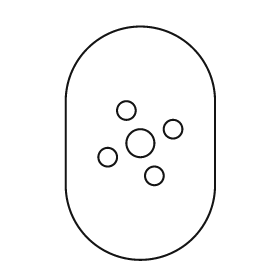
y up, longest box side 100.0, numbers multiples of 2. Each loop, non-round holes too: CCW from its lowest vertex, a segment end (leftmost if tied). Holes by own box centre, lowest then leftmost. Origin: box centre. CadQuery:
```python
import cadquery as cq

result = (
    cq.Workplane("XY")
    .moveTo(-32.0, -18.0)
    .threePointArc((0.0, -50.0), (32.0, -18.0))
    .lineTo(32.0, 18.0)
    .threePointArc((0.0, 50.0), (-32.0, 18.0))
    .close()
    .moveTo(6.0, -14.0)
    .circle(4.0)
    .moveTo(-14.0, -6.0)
    .circle(4.0)
    .moveTo(0.0, 0.0)
    .circle(6.0)
    .moveTo(14.0, 6.0)
    .circle(4.0)
    .moveTo(-6.0, 14.0)
    .circle(4.0)
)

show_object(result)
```